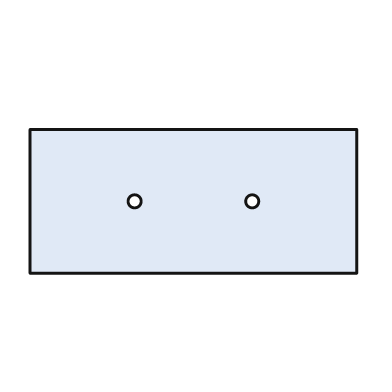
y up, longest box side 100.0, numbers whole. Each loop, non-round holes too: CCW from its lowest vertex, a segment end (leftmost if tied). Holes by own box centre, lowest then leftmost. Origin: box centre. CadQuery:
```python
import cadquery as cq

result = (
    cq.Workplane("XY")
    .moveTo(-50.0, -22.0)
    .lineTo(50.0, -22.0)
    .lineTo(50.0, 22.0)
    .lineTo(-50.0, 22.0)
    .close()
    .moveTo(-18.0, 0.0)
    .circle(2.0)
    .moveTo(18.0, 0.0)
    .circle(2.0)
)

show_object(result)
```